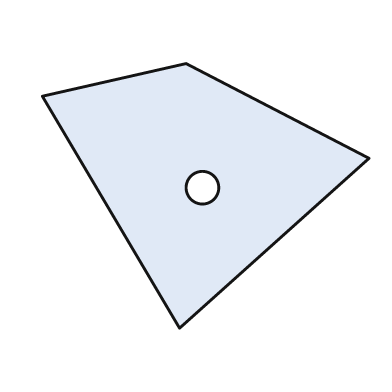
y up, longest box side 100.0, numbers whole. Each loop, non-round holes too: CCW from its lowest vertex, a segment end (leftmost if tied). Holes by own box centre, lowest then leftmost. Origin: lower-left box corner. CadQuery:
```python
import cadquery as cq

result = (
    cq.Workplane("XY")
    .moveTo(42.0, 0.0)
    .lineTo(100.0, 52.0)
    .lineTo(44.0, 81.0)
    .lineTo(0.0, 71.0)
    .close()
    .moveTo(49.0, 43.0)
    .circle(5.0)
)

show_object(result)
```